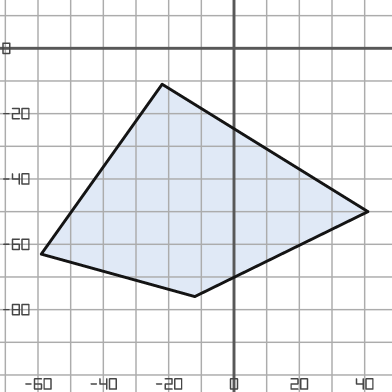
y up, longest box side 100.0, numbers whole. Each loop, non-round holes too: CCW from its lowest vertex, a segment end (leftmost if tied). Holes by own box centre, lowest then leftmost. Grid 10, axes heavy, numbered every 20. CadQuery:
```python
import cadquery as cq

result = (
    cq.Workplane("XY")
    .moveTo(-12.0, -76.0)
    .lineTo(41.0, -50.0)
    .lineTo(-22.0, -11.0)
    .lineTo(-59.0, -63.0)
    .close()
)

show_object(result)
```